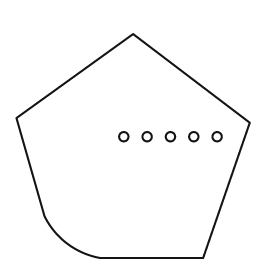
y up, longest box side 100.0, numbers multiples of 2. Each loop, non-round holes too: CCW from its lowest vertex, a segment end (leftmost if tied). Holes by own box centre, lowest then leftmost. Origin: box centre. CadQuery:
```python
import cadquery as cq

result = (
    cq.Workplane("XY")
    .moveTo(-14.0, -48.0)
    .lineTo(30.0, -48.0)
    .lineTo(50.0, 10.0)
    .lineTo(0.0, 48.0)
    .lineTo(-50.0, 12.0)
    .lineTo(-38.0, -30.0)
    .threePointArc((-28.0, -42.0), (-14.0, -48.0))
    .close()
    .moveTo(-4.0, 4.0)
    .circle(2.0)
    .moveTo(6.0, 4.0)
    .circle(2.0)
    .moveTo(16.0, 4.0)
    .circle(2.0)
    .moveTo(26.0, 4.0)
    .circle(2.0)
    .moveTo(36.0, 4.0)
    .circle(2.0)
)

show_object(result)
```